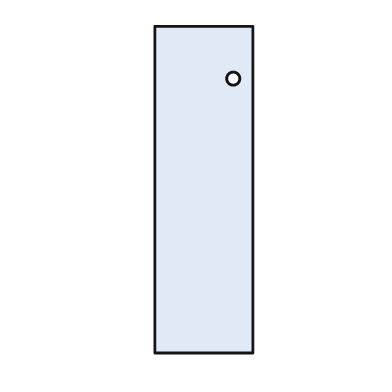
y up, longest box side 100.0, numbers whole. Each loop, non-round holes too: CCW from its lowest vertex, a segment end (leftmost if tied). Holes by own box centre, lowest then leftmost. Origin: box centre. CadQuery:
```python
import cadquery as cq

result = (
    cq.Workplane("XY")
    .moveTo(-15.0, -50.0)
    .lineTo(15.0, -50.0)
    .lineTo(15.0, 50.0)
    .lineTo(-15.0, 50.0)
    .close()
    .moveTo(9.0, 34.0)
    .circle(2.0)
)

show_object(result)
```